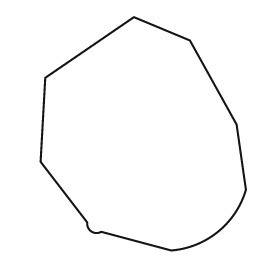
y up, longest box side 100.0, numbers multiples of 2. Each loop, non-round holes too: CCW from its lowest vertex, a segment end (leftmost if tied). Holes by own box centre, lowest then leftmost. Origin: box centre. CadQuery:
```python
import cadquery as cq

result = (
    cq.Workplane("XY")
    .moveTo(12.0, -50.0)
    .threePointArc((32.0, -42.0), (44.0, -24.0))
    .lineTo(40.0, 4.0)
    .lineTo(20.0, 40.0)
    .lineTo(-4.0, 50.0)
    .lineTo(-42.0, 24.0)
    .lineTo(-44.0, -12.0)
    .lineTo(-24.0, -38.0)
    .threePointArc((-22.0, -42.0), (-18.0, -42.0))
    .close()
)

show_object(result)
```